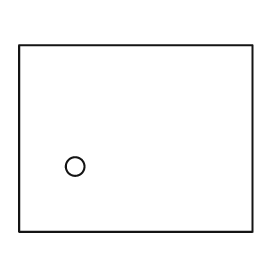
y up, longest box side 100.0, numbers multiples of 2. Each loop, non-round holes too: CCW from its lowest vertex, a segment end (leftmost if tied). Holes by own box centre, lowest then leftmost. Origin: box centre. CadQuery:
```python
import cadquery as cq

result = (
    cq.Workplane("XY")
    .moveTo(-50.0, -40.0)
    .lineTo(50.0, -40.0)
    .lineTo(50.0, 40.0)
    .lineTo(-50.0, 40.0)
    .close()
    .moveTo(-26.0, -12.0)
    .circle(4.0)
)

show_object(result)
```